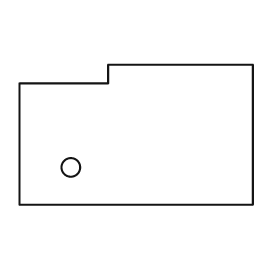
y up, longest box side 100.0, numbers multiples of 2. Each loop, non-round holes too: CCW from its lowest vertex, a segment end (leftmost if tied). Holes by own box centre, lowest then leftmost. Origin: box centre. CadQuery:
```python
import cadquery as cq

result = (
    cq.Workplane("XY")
    .moveTo(-50.0, -30.0)
    .lineTo(50.0, -30.0)
    .lineTo(50.0, 30.0)
    .lineTo(-12.0, 30.0)
    .lineTo(-12.0, 22.0)
    .lineTo(-50.0, 22.0)
    .close()
    .moveTo(-28.0, -14.0)
    .circle(4.0)
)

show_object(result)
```